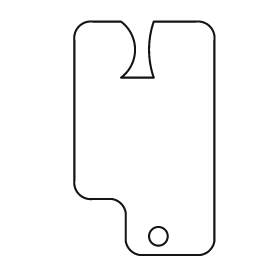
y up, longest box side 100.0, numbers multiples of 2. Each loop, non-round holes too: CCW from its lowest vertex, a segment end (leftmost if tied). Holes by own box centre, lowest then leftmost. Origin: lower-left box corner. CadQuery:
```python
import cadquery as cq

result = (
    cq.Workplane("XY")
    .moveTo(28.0, 0.0)
    .lineTo(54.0, 0.0)
    .threePointArc((58.0, 2.0), (60.0, 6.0))
    .lineTo(60.0, 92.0)
    .threePointArc((58.0, 98.0), (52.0, 100.0))
    .lineTo(34.0, 100.0)
    .threePointArc((32.0, 88.0), (34.0, 76.0))
    .lineTo(20.0, 76.0)
    .threePointArc((26.0, 88.0), (20.0, 100.0))
    .lineTo(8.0, 100.0)
    .threePointArc((2.0, 98.0), (0.0, 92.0))
    .lineTo(0.0, 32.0)
    .threePointArc((2.0, 26.0), (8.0, 24.0))
    .lineTo(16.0, 24.0)
    .threePointArc((20.0, 22.0), (22.0, 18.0))
    .lineTo(22.0, 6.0)
    .threePointArc((24.0, 2.0), (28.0, 0.0))
    .close()
    .moveTo(36.0, 8.0)
    .circle(4.0)
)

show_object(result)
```